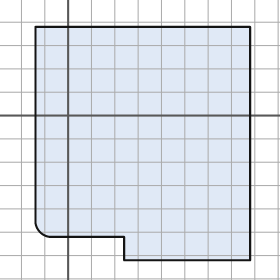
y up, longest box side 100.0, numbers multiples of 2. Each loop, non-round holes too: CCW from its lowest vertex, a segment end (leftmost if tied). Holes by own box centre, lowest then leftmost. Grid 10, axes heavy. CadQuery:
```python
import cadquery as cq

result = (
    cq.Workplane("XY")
    .moveTo(24.0, -62.0)
    .lineTo(78.0, -62.0)
    .lineTo(78.0, 38.0)
    .lineTo(-14.0, 38.0)
    .lineTo(-14.0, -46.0)
    .threePointArc((-12.0, -50.0), (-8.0, -52.0))
    .lineTo(24.0, -52.0)
    .close()
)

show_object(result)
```